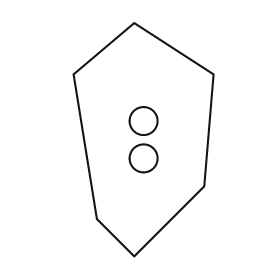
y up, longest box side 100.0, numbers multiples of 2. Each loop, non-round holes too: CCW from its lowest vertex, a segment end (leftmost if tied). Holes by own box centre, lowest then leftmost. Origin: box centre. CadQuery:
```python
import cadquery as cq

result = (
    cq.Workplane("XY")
    .moveTo(-4.0, -50.0)
    .lineTo(26.0, -20.0)
    .lineTo(30.0, 28.0)
    .lineTo(-4.0, 50.0)
    .lineTo(-30.0, 28.0)
    .lineTo(-20.0, -34.0)
    .close()
    .moveTo(0.0, -8.0)
    .circle(6.0)
    .moveTo(0.0, 8.0)
    .circle(6.0)
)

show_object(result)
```